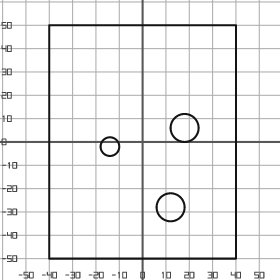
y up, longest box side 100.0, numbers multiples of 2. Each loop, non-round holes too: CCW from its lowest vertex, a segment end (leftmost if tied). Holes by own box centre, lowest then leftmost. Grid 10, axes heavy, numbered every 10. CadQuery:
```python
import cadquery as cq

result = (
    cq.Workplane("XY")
    .moveTo(-40.0, -50.0)
    .lineTo(40.0, -50.0)
    .lineTo(40.0, 50.0)
    .lineTo(-40.0, 50.0)
    .close()
    .moveTo(12.0, -28.0)
    .circle(6.0)
    .moveTo(-14.0, -2.0)
    .circle(4.0)
    .moveTo(18.0, 6.0)
    .circle(6.0)
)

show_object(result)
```